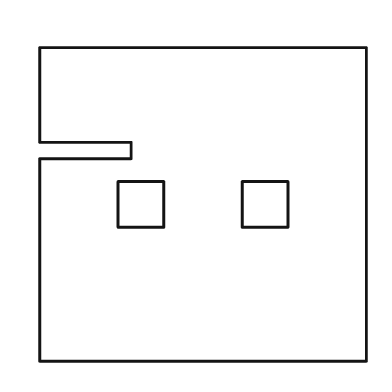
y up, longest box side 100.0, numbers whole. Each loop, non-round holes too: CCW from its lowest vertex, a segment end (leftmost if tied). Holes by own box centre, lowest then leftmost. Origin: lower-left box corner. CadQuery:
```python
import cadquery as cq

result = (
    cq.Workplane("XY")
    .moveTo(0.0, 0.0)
    .lineTo(100.0, 0.0)
    .lineTo(100.0, 96.0)
    .lineTo(0.0, 96.0)
    .lineTo(0.0, 67.0)
    .lineTo(28.0, 67.0)
    .lineTo(28.0, 62.0)
    .lineTo(0.0, 62.0)
    .close()
    .moveTo(24.0, 41.0)
    .lineTo(38.0, 41.0)
    .lineTo(38.0, 55.0)
    .lineTo(24.0, 55.0)
    .close()
    .moveTo(62.0, 41.0)
    .lineTo(76.0, 41.0)
    .lineTo(76.0, 55.0)
    .lineTo(62.0, 55.0)
    .close()
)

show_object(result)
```